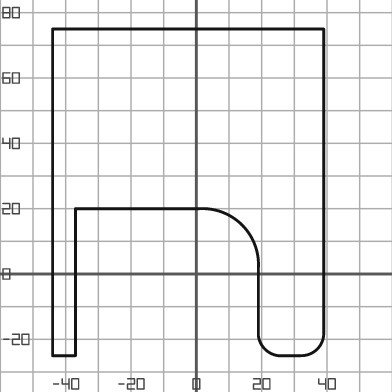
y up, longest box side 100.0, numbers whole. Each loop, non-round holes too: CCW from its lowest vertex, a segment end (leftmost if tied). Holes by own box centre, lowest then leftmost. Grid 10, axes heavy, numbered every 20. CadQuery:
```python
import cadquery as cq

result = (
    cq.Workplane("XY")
    .moveTo(-44.0, -25.0)
    .lineTo(-37.0, -25.0)
    .lineTo(-37.0, 20.0)
    .lineTo(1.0, 20.0)
    .threePointArc((14.0, 15.0), (19.0, 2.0))
    .lineTo(19.0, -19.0)
    .threePointArc((21.0, -23.0), (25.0, -25.0))
    .lineTo(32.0, -25.0)
    .threePointArc((37.0, -23.0), (39.0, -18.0))
    .lineTo(39.0, 75.0)
    .lineTo(-44.0, 75.0)
    .close()
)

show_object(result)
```